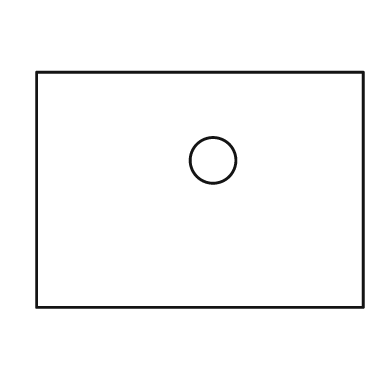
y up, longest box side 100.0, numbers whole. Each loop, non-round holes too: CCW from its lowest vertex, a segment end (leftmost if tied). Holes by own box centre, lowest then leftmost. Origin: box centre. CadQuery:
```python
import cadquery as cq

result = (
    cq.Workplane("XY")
    .moveTo(-50.0, -36.0)
    .lineTo(50.0, -36.0)
    .lineTo(50.0, 36.0)
    .lineTo(-50.0, 36.0)
    .close()
    .moveTo(4.0, 9.0)
    .circle(7.0)
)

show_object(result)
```